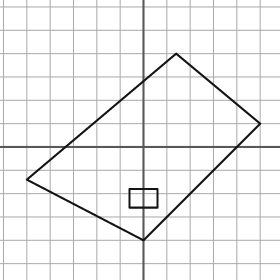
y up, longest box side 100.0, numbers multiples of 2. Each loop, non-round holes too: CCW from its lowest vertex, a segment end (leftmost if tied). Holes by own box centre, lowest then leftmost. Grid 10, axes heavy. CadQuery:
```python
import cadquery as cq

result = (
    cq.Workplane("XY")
    .moveTo(0.0, -40.0)
    .lineTo(50.0, 10.0)
    .lineTo(14.0, 40.0)
    .lineTo(-50.0, -14.0)
    .close()
    .moveTo(-6.0, -26.0)
    .lineTo(6.0, -26.0)
    .lineTo(6.0, -18.0)
    .lineTo(-6.0, -18.0)
    .close()
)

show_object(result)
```